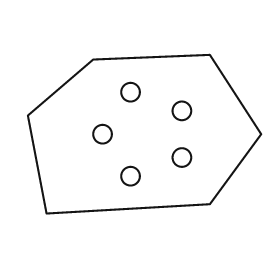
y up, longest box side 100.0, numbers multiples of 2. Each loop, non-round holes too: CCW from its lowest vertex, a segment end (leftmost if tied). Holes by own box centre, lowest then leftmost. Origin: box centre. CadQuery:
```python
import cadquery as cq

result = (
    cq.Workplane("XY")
    .moveTo(-42.0, -34.0)
    .lineTo(28.0, -30.0)
    .lineTo(50.0, 0.0)
    .lineTo(28.0, 34.0)
    .lineTo(-22.0, 32.0)
    .lineTo(-50.0, 8.0)
    .close()
    .moveTo(-6.0, -18.0)
    .circle(4.0)
    .moveTo(16.0, -10.0)
    .circle(4.0)
    .moveTo(-18.0, 0.0)
    .circle(4.0)
    .moveTo(16.0, 10.0)
    .circle(4.0)
    .moveTo(-6.0, 18.0)
    .circle(4.0)
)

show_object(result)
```